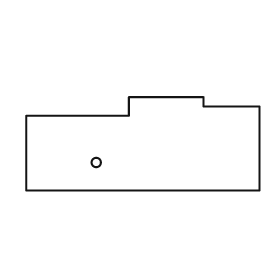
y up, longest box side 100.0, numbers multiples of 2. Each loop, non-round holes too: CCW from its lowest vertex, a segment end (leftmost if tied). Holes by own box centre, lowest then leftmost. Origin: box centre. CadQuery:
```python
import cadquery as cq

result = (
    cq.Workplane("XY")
    .moveTo(-50.0, -20.0)
    .lineTo(50.0, -20.0)
    .lineTo(50.0, 16.0)
    .lineTo(26.0, 16.0)
    .lineTo(26.0, 20.0)
    .lineTo(-6.0, 20.0)
    .lineTo(-6.0, 12.0)
    .lineTo(-50.0, 12.0)
    .close()
    .moveTo(-20.0, -8.0)
    .circle(2.0)
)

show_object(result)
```